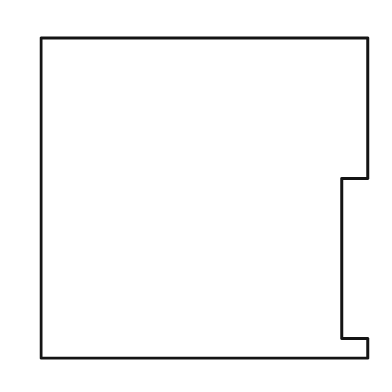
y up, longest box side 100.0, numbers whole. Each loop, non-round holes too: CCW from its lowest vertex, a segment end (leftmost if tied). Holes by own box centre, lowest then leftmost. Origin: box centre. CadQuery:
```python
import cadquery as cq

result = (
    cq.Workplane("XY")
    .moveTo(-50.0, -49.0)
    .lineTo(50.0, -49.0)
    .lineTo(50.0, -43.0)
    .lineTo(42.0, -43.0)
    .lineTo(42.0, 6.0)
    .lineTo(50.0, 6.0)
    .lineTo(50.0, 49.0)
    .lineTo(-50.0, 49.0)
    .close()
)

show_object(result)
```